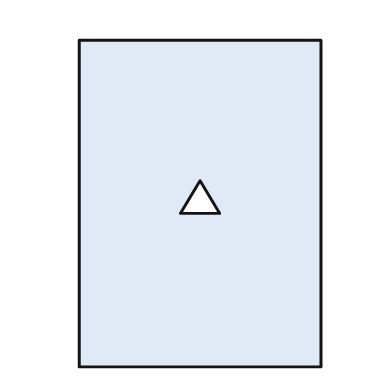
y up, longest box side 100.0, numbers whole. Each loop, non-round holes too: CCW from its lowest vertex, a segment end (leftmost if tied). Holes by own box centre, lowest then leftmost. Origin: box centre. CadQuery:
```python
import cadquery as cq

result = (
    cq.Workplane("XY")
    .moveTo(-37.0, -50.0)
    .lineTo(37.0, -50.0)
    .lineTo(37.0, 50.0)
    .lineTo(-37.0, 50.0)
    .close()
    .moveTo(-6.0, -3.0)
    .lineTo(6.0, -3.0)
    .lineTo(0.0, 7.0)
    .close()
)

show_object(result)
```